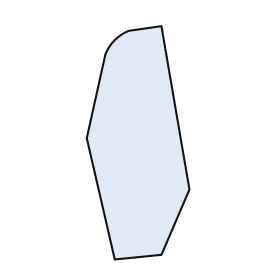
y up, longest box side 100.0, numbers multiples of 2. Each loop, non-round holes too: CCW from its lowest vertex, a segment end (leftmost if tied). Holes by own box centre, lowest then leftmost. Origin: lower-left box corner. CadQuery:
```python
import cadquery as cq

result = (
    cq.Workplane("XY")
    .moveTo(12.0, 0.0)
    .lineTo(32.0, 2.0)
    .lineTo(44.0, 30.0)
    .lineTo(32.0, 100.0)
    .lineTo(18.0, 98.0)
    .threePointArc((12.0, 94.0), (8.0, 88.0))
    .lineTo(0.0, 52.0)
    .close()
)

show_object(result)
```